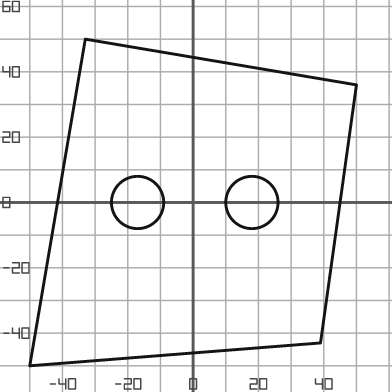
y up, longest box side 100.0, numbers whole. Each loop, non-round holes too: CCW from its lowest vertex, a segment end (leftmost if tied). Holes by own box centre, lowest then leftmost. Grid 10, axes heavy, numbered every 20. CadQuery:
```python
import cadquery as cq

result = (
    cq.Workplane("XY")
    .moveTo(-50.0, -50.0)
    .lineTo(39.0, -43.0)
    .lineTo(50.0, 36.0)
    .lineTo(-33.0, 50.0)
    .close()
    .moveTo(-17.0, 0.0)
    .circle(8.0)
    .moveTo(18.0, 0.0)
    .circle(8.0)
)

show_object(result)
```